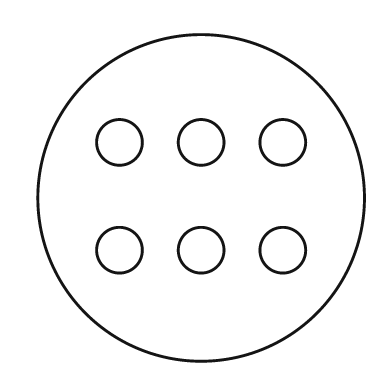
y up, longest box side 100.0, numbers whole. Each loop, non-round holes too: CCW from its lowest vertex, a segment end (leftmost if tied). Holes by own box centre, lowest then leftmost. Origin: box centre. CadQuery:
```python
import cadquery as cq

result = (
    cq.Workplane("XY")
    .moveTo(0.0, 0.0)
    .circle(50.0)
    .moveTo(-25.0, -16.0)
    .circle(7.0)
    .moveTo(0.0, -16.0)
    .circle(7.0)
    .moveTo(25.0, -16.0)
    .circle(7.0)
    .moveTo(-25.0, 17.0)
    .circle(7.0)
    .moveTo(0.0, 17.0)
    .circle(7.0)
    .moveTo(25.0, 17.0)
    .circle(7.0)
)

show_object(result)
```